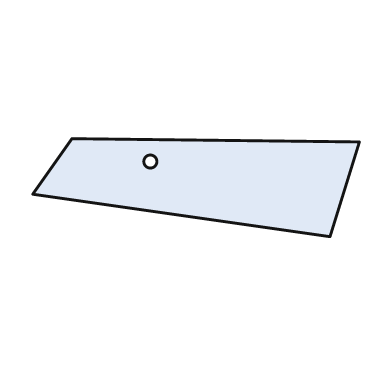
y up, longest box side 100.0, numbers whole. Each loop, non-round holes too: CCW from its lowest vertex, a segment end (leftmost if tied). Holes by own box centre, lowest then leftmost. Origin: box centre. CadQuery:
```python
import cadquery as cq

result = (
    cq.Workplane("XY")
    .moveTo(41.0, -15.0)
    .lineTo(50.0, 14.0)
    .lineTo(-38.0, 15.0)
    .lineTo(-50.0, -2.0)
    .close()
    .moveTo(-14.0, 8.0)
    .circle(2.0)
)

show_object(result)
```